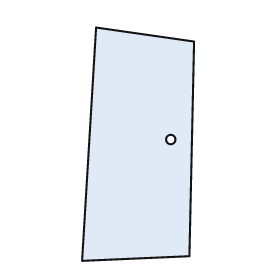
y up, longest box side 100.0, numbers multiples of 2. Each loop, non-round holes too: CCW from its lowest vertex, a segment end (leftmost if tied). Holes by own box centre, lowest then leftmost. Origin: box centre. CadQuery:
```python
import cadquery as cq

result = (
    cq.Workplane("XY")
    .moveTo(-24.0, -50.0)
    .lineTo(22.0, -48.0)
    .lineTo(24.0, 44.0)
    .lineTo(-18.0, 50.0)
    .close()
    .moveTo(14.0, 2.0)
    .circle(2.0)
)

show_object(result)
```